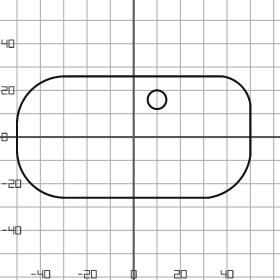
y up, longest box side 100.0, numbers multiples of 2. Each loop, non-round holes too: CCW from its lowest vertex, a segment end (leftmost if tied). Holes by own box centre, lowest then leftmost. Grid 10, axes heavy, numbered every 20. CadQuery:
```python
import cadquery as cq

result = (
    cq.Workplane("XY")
    .moveTo(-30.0, -26.0)
    .lineTo(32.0, -26.0)
    .threePointArc((44.0, -20.0), (50.0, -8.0))
    .lineTo(50.0, 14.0)
    .threePointArc((46.0, 22.0), (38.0, 26.0))
    .lineTo(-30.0, 26.0)
    .threePointArc((-44.0, 20.0), (-50.0, 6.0))
    .lineTo(-50.0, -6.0)
    .threePointArc((-44.0, -20.0), (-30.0, -26.0))
    .close()
    .moveTo(10.0, 16.0)
    .circle(4.0)
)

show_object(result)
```